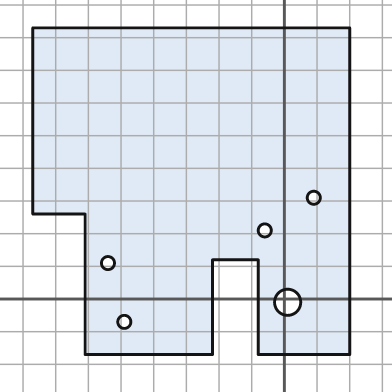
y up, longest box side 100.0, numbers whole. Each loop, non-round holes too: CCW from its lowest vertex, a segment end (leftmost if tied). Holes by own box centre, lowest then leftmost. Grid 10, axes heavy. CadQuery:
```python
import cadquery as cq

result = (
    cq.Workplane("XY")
    .moveTo(-61.0, -17.0)
    .lineTo(-22.0, -17.0)
    .lineTo(-22.0, 12.0)
    .lineTo(-8.0, 12.0)
    .lineTo(-8.0, -17.0)
    .lineTo(20.0, -17.0)
    .lineTo(20.0, 83.0)
    .lineTo(-77.0, 83.0)
    .lineTo(-77.0, 26.0)
    .lineTo(-61.0, 26.0)
    .close()
    .moveTo(-49.0, -7.0)
    .circle(2.0)
    .moveTo(1.0, -1.0)
    .circle(4.0)
    .moveTo(-54.0, 11.0)
    .circle(2.0)
    .moveTo(-6.0, 21.0)
    .circle(2.0)
    .moveTo(9.0, 31.0)
    .circle(2.0)
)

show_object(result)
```